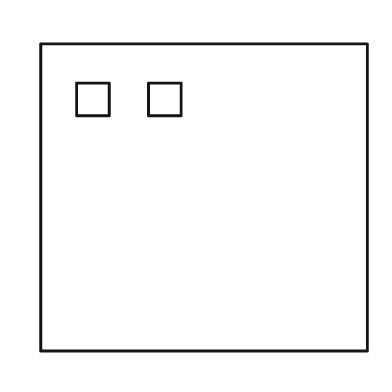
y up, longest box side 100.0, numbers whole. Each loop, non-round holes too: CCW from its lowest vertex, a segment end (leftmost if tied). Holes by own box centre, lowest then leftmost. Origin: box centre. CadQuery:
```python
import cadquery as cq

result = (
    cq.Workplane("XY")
    .moveTo(-50.0, -47.0)
    .lineTo(50.0, -47.0)
    .lineTo(50.0, 47.0)
    .lineTo(-50.0, 47.0)
    .close()
    .moveTo(-39.0, 25.0)
    .lineTo(-29.0, 25.0)
    .lineTo(-29.0, 35.0)
    .lineTo(-39.0, 35.0)
    .close()
    .moveTo(-17.0, 25.0)
    .lineTo(-7.0, 25.0)
    .lineTo(-7.0, 35.0)
    .lineTo(-17.0, 35.0)
    .close()
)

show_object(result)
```